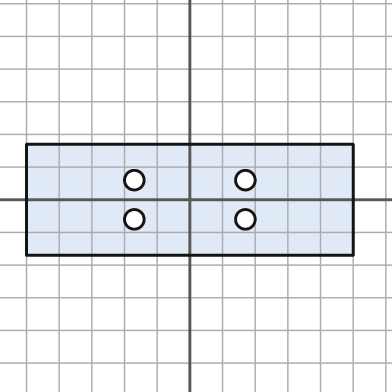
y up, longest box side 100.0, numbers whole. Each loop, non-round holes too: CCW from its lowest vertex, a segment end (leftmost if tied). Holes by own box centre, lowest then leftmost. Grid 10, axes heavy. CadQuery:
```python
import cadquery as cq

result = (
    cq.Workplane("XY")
    .moveTo(-50.0, -17.0)
    .lineTo(50.0, -17.0)
    .lineTo(50.0, 17.0)
    .lineTo(-50.0, 17.0)
    .close()
    .moveTo(-17.0, -6.0)
    .circle(3.0)
    .moveTo(17.0, -6.0)
    .circle(3.0)
    .moveTo(-17.0, 6.0)
    .circle(3.0)
    .moveTo(17.0, 6.0)
    .circle(3.0)
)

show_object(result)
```